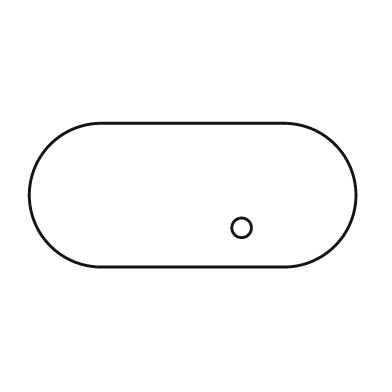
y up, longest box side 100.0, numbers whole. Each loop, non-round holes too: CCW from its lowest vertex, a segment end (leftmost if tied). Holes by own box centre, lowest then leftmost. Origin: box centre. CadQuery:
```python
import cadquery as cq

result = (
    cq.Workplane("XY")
    .moveTo(-28.0, -22.0)
    .lineTo(28.0, -22.0)
    .threePointArc((50.0, 0.0), (28.0, 22.0))
    .lineTo(-28.0, 22.0)
    .threePointArc((-50.0, 0.0), (-28.0, -22.0))
    .close()
    .moveTo(15.0, -10.0)
    .circle(3.0)
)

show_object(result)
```